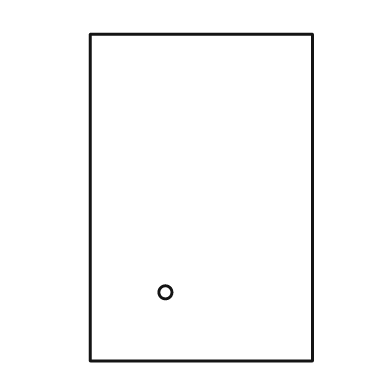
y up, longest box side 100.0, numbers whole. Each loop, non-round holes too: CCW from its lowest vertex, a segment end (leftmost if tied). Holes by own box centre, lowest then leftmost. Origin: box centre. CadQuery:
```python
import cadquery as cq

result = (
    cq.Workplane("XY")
    .moveTo(-34.0, -50.0)
    .lineTo(34.0, -50.0)
    .lineTo(34.0, 50.0)
    .lineTo(-34.0, 50.0)
    .close()
    .moveTo(-11.0, -29.0)
    .circle(2.0)
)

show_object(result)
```